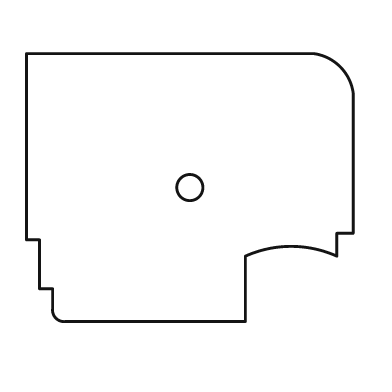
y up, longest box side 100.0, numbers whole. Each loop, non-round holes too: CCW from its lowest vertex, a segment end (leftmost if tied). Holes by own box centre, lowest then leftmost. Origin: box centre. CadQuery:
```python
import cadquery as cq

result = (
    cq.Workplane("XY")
    .moveTo(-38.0, -41.0)
    .lineTo(17.0, -41.0)
    .lineTo(17.0, -21.0)
    .threePointArc((31.0, -18.0), (45.0, -21.0))
    .lineTo(45.0, -14.0)
    .lineTo(50.0, -14.0)
    .lineTo(50.0, 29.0)
    .threePointArc((46.0, 37.0), (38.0, 41.0))
    .lineTo(-50.0, 41.0)
    .lineTo(-50.0, -16.0)
    .lineTo(-46.0, -16.0)
    .lineTo(-46.0, -31.0)
    .lineTo(-42.0, -31.0)
    .lineTo(-42.0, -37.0)
    .threePointArc((-41.0, -40.0), (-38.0, -41.0))
    .close()
    .moveTo(0.0, 0.0)
    .circle(4.0)
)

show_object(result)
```